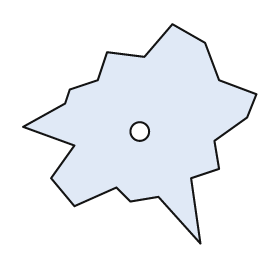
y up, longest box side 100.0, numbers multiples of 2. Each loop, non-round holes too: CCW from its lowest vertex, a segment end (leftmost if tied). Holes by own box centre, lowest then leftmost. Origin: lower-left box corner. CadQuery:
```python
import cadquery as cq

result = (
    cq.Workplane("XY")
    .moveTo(76.0, 0.0)
    .lineTo(72.0, 28.0)
    .lineTo(84.0, 32.0)
    .lineTo(82.0, 44.0)
    .lineTo(96.0, 54.0)
    .lineTo(100.0, 64.0)
    .lineTo(84.0, 70.0)
    .lineTo(78.0, 86.0)
    .lineTo(64.0, 94.0)
    .lineTo(52.0, 80.0)
    .lineTo(36.0, 82.0)
    .lineTo(32.0, 70.0)
    .lineTo(20.0, 66.0)
    .lineTo(18.0, 60.0)
    .lineTo(0.0, 50.0)
    .lineTo(22.0, 42.0)
    .lineTo(12.0, 28.0)
    .lineTo(22.0, 16.0)
    .lineTo(40.0, 24.0)
    .lineTo(46.0, 18.0)
    .lineTo(58.0, 20.0)
    .close()
    .moveTo(50.0, 48.0)
    .circle(4.0)
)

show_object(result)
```